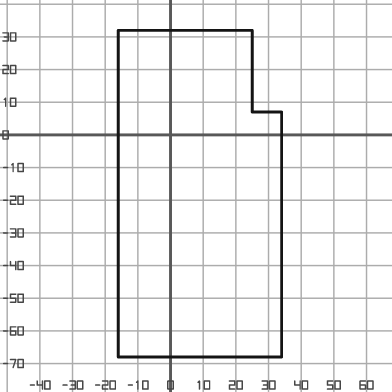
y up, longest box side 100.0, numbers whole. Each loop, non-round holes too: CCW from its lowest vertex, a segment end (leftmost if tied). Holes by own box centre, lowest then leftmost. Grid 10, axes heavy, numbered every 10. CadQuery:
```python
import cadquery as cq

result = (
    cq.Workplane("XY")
    .moveTo(-16.0, -68.0)
    .lineTo(34.0, -68.0)
    .lineTo(34.0, 7.0)
    .lineTo(25.0, 7.0)
    .lineTo(25.0, 32.0)
    .lineTo(-16.0, 32.0)
    .close()
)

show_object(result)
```